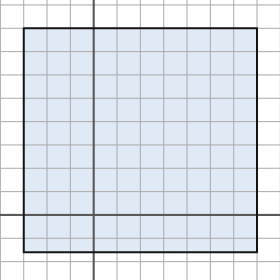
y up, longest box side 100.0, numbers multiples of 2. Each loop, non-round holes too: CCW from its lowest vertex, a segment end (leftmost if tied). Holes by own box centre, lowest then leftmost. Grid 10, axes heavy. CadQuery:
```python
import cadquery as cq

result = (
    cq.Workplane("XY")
    .moveTo(-30.0, -16.0)
    .lineTo(70.0, -16.0)
    .lineTo(70.0, 80.0)
    .lineTo(-30.0, 80.0)
    .close()
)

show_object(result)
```